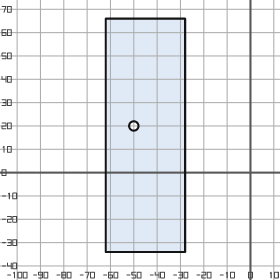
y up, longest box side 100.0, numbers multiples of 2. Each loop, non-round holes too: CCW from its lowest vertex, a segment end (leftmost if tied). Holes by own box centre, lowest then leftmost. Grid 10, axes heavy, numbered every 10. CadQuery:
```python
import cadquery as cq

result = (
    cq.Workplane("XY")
    .moveTo(-62.0, -34.0)
    .lineTo(-28.0, -34.0)
    .lineTo(-28.0, 66.0)
    .lineTo(-62.0, 66.0)
    .close()
    .moveTo(-50.0, 20.0)
    .circle(2.0)
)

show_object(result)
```